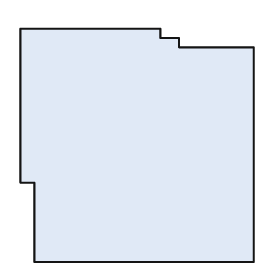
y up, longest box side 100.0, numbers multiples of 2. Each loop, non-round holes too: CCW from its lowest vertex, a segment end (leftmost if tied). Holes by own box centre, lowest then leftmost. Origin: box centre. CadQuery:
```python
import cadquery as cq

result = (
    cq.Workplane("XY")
    .moveTo(-44.0, -50.0)
    .lineTo(50.0, -50.0)
    .lineTo(50.0, 42.0)
    .lineTo(18.0, 42.0)
    .lineTo(18.0, 46.0)
    .lineTo(10.0, 46.0)
    .lineTo(10.0, 50.0)
    .lineTo(-50.0, 50.0)
    .lineTo(-50.0, -16.0)
    .lineTo(-44.0, -16.0)
    .close()
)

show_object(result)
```